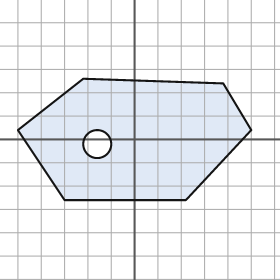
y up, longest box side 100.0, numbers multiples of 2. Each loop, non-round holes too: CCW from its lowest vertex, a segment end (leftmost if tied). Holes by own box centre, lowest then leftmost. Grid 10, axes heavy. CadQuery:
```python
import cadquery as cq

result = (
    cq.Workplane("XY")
    .moveTo(-30.0, -26.0)
    .lineTo(22.0, -26.0)
    .lineTo(50.0, 4.0)
    .lineTo(38.0, 24.0)
    .lineTo(-22.0, 26.0)
    .lineTo(-50.0, 4.0)
    .close()
    .moveTo(-16.0, -2.0)
    .circle(6.0)
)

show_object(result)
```